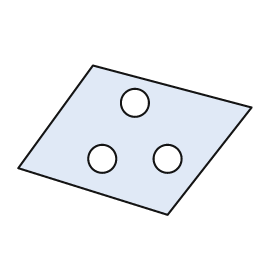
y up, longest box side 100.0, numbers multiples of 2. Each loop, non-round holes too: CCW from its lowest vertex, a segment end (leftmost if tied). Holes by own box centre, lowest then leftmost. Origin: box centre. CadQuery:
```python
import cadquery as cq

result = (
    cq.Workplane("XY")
    .moveTo(14.0, -32.0)
    .lineTo(50.0, 14.0)
    .lineTo(-18.0, 32.0)
    .lineTo(-50.0, -12.0)
    .close()
    .moveTo(-14.0, -8.0)
    .circle(6.0)
    .moveTo(14.0, -8.0)
    .circle(6.0)
    .moveTo(0.0, 16.0)
    .circle(6.0)
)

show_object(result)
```